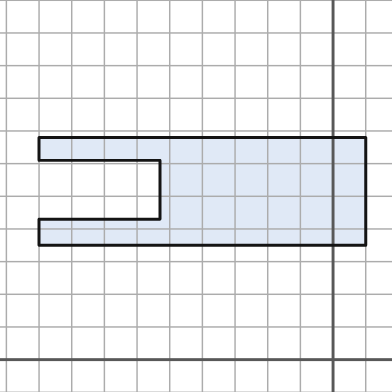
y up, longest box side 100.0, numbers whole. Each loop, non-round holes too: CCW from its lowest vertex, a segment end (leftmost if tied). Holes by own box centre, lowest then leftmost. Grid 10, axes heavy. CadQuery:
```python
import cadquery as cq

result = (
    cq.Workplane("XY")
    .moveTo(-90.0, 35.0)
    .lineTo(10.0, 35.0)
    .lineTo(10.0, 68.0)
    .lineTo(-90.0, 68.0)
    .lineTo(-90.0, 61.0)
    .lineTo(-53.0, 61.0)
    .lineTo(-53.0, 43.0)
    .lineTo(-90.0, 43.0)
    .close()
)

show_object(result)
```